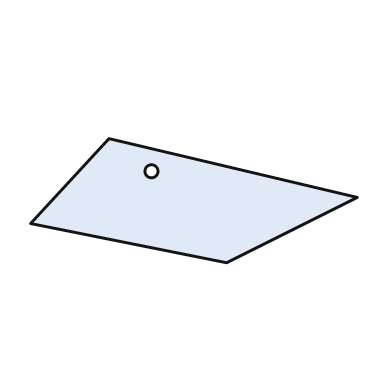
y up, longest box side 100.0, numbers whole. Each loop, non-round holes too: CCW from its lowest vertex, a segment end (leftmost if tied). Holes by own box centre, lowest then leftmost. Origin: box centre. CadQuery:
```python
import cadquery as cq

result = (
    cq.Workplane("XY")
    .moveTo(10.0, -19.0)
    .lineTo(50.0, 1.0)
    .lineTo(-26.0, 19.0)
    .lineTo(-50.0, -7.0)
    .close()
    .moveTo(-13.0, 9.0)
    .circle(2.0)
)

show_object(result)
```